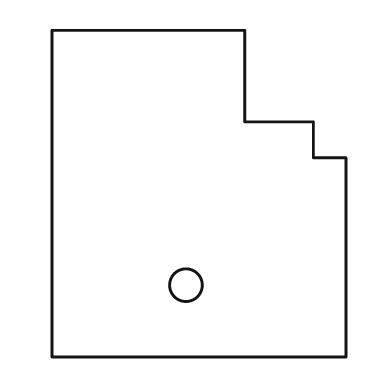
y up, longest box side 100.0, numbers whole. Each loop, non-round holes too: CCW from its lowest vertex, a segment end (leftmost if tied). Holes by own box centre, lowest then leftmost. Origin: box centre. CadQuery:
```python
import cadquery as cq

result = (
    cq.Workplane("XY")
    .moveTo(-45.0, -50.0)
    .lineTo(45.0, -50.0)
    .lineTo(45.0, 11.0)
    .lineTo(35.0, 11.0)
    .lineTo(35.0, 22.0)
    .lineTo(14.0, 22.0)
    .lineTo(14.0, 50.0)
    .lineTo(-45.0, 50.0)
    .close()
    .moveTo(-4.0, -28.0)
    .circle(5.0)
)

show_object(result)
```